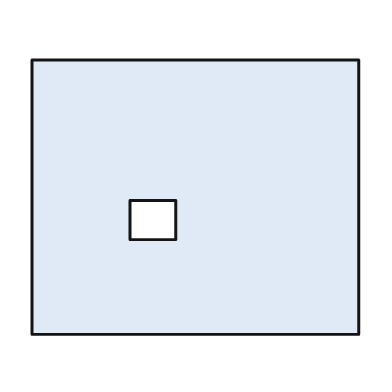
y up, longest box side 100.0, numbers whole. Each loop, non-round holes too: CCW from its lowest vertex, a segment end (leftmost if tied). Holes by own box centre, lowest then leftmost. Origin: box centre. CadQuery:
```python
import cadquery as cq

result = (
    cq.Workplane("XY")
    .moveTo(-50.0, -42.0)
    .lineTo(50.0, -42.0)
    .lineTo(50.0, 42.0)
    .lineTo(-50.0, 42.0)
    .close()
    .moveTo(-20.0, -13.0)
    .lineTo(-6.0, -13.0)
    .lineTo(-6.0, -1.0)
    .lineTo(-20.0, -1.0)
    .close()
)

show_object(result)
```